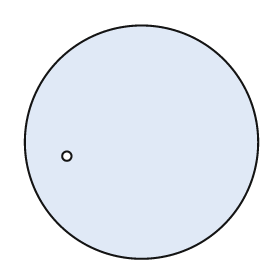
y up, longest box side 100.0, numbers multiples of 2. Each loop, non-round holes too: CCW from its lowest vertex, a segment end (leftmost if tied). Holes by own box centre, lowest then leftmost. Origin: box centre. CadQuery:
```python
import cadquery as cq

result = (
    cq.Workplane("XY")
    .moveTo(0.0, 0.0)
    .circle(50.0)
    .moveTo(-32.0, -6.0)
    .circle(2.0)
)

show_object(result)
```